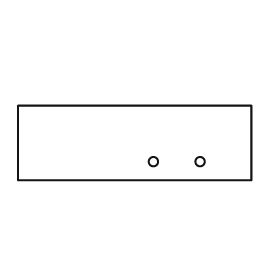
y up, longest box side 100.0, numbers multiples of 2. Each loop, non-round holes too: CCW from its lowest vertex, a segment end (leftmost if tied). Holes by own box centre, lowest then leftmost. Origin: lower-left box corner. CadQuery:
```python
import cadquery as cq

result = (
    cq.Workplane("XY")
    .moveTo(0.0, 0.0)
    .lineTo(100.0, 0.0)
    .lineTo(100.0, 32.0)
    .lineTo(0.0, 32.0)
    .close()
    .moveTo(58.0, 8.0)
    .circle(2.0)
    .moveTo(78.0, 8.0)
    .circle(2.0)
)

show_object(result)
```